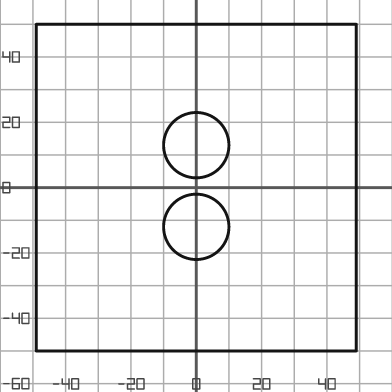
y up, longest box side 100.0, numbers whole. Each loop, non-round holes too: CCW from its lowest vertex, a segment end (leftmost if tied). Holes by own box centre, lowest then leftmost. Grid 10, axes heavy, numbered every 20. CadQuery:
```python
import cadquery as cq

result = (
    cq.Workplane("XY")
    .moveTo(-49.0, -50.0)
    .lineTo(49.0, -50.0)
    .lineTo(49.0, 50.0)
    .lineTo(-49.0, 50.0)
    .close()
    .moveTo(0.0, -12.0)
    .circle(10.0)
    .moveTo(0.0, 13.0)
    .circle(10.0)
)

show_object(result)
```